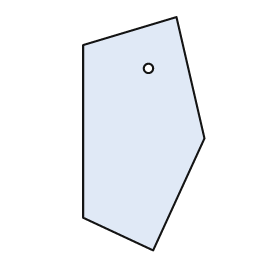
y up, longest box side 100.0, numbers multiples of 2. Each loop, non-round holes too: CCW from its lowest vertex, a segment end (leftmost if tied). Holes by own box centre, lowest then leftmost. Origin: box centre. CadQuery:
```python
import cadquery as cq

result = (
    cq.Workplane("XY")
    .moveTo(4.0, -50.0)
    .lineTo(26.0, -2.0)
    .lineTo(14.0, 50.0)
    .lineTo(-26.0, 38.0)
    .lineTo(-26.0, -36.0)
    .close()
    .moveTo(2.0, 28.0)
    .circle(2.0)
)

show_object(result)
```